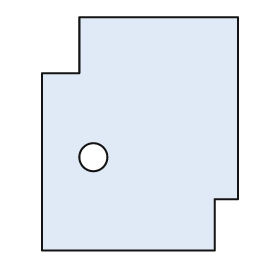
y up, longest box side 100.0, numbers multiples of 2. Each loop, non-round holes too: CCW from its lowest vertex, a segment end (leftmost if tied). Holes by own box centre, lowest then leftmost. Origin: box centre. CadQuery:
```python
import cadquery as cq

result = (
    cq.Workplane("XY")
    .moveTo(-42.0, -50.0)
    .lineTo(32.0, -50.0)
    .lineTo(32.0, -28.0)
    .lineTo(42.0, -28.0)
    .lineTo(42.0, 50.0)
    .lineTo(-26.0, 50.0)
    .lineTo(-26.0, 26.0)
    .lineTo(-42.0, 26.0)
    .close()
    .moveTo(-20.0, -10.0)
    .circle(6.0)
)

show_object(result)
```